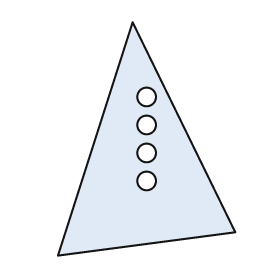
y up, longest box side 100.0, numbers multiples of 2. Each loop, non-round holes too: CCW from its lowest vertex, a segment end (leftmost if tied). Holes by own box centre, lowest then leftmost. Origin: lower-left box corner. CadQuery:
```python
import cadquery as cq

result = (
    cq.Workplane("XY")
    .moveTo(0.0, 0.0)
    .lineTo(76.0, 10.0)
    .lineTo(32.0, 100.0)
    .close()
    .moveTo(38.0, 32.0)
    .circle(4.0)
    .moveTo(38.0, 44.0)
    .circle(4.0)
    .moveTo(38.0, 56.0)
    .circle(4.0)
    .moveTo(38.0, 68.0)
    .circle(4.0)
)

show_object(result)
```